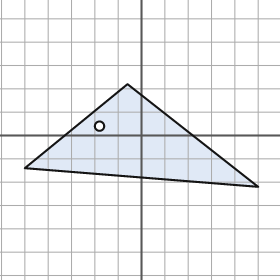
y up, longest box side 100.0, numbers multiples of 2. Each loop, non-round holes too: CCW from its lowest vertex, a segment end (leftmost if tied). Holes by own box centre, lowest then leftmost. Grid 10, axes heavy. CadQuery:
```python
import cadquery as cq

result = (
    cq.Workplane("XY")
    .moveTo(50.0, -22.0)
    .lineTo(-6.0, 22.0)
    .lineTo(-50.0, -14.0)
    .close()
    .moveTo(-18.0, 4.0)
    .circle(2.0)
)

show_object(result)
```